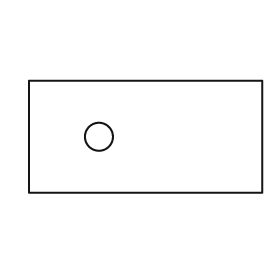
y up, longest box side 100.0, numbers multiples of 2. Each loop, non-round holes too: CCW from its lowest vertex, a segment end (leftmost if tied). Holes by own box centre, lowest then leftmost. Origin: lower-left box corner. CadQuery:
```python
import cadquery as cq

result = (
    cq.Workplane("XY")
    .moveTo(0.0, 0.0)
    .lineTo(100.0, 0.0)
    .lineTo(100.0, 48.0)
    .lineTo(0.0, 48.0)
    .close()
    .moveTo(30.0, 24.0)
    .circle(6.0)
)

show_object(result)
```